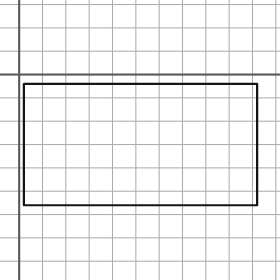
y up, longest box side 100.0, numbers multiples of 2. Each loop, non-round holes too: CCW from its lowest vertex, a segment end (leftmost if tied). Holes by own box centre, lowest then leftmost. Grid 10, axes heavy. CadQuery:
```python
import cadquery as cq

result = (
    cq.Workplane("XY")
    .moveTo(2.0, -56.0)
    .lineTo(102.0, -56.0)
    .lineTo(102.0, -4.0)
    .lineTo(2.0, -4.0)
    .close()
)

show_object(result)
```